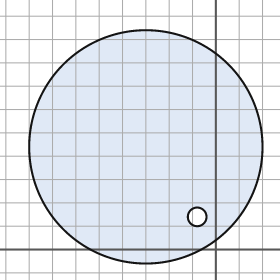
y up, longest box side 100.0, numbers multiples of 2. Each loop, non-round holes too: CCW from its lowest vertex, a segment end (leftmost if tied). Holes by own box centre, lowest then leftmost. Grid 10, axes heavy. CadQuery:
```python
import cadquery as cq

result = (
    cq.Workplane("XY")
    .moveTo(-30.0, 44.0)
    .circle(50.0)
    .moveTo(-8.0, 14.0)
    .circle(4.0)
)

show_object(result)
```